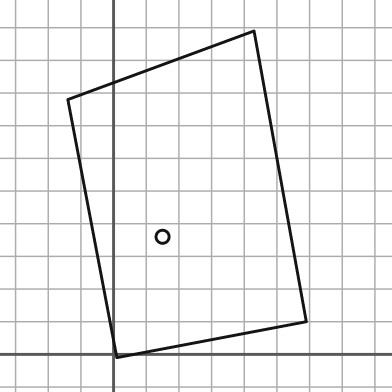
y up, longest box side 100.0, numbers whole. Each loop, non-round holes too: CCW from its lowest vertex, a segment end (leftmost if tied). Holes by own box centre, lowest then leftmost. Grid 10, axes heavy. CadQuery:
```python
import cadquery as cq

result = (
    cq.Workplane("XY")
    .moveTo(1.0, -1.0)
    .lineTo(59.0, 10.0)
    .lineTo(43.0, 99.0)
    .lineTo(-14.0, 78.0)
    .close()
    .moveTo(15.0, 36.0)
    .circle(2.0)
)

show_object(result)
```